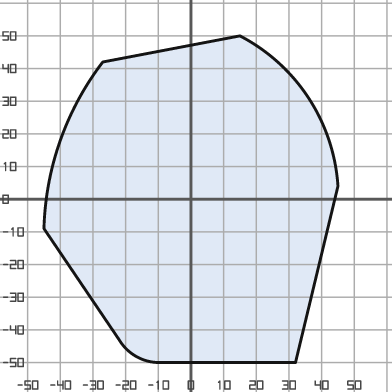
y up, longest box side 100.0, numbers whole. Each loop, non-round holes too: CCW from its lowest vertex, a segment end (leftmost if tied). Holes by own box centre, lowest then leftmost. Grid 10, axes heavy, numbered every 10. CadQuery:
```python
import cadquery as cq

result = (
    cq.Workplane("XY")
    .moveTo(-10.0, -50.0)
    .lineTo(32.0, -50.0)
    .lineTo(45.0, 4.0)
    .threePointArc((36.0, 31.0), (15.0, 50.0))
    .lineTo(-27.0, 42.0)
    .threePointArc((-40.0, 18.0), (-45.0, -9.0))
    .lineTo(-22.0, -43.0)
    .threePointArc((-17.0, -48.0), (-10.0, -50.0))
    .close()
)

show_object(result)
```